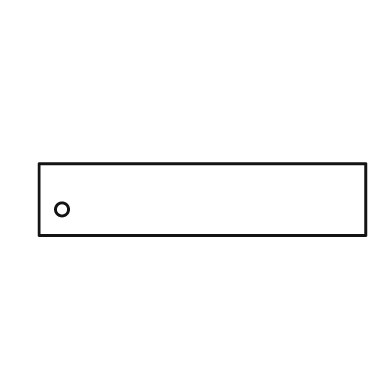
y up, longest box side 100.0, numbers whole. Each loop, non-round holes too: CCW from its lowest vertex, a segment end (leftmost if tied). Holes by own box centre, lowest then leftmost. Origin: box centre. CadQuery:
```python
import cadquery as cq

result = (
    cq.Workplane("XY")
    .moveTo(-50.0, -11.0)
    .lineTo(50.0, -11.0)
    .lineTo(50.0, 11.0)
    .lineTo(-50.0, 11.0)
    .close()
    .moveTo(-43.0, -3.0)
    .circle(2.0)
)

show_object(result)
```